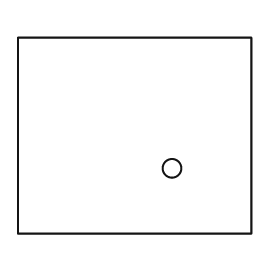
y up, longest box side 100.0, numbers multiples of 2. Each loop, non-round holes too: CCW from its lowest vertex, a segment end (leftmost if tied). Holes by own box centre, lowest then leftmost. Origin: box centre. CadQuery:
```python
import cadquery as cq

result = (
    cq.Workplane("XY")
    .moveTo(-50.0, -42.0)
    .lineTo(50.0, -42.0)
    .lineTo(50.0, 42.0)
    .lineTo(-50.0, 42.0)
    .close()
    .moveTo(16.0, -14.0)
    .circle(4.0)
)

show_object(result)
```